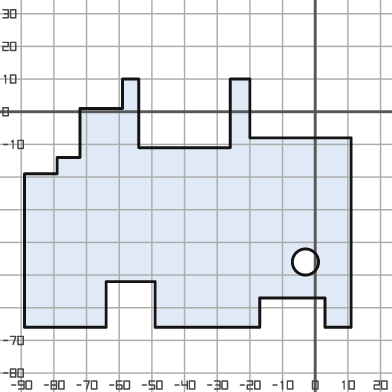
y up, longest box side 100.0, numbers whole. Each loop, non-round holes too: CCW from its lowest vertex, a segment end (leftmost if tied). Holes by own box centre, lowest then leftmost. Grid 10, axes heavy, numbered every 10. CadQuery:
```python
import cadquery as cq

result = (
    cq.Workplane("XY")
    .moveTo(-89.0, -66.0)
    .lineTo(-64.0, -66.0)
    .lineTo(-64.0, -52.0)
    .lineTo(-49.0, -52.0)
    .lineTo(-49.0, -66.0)
    .lineTo(-17.0, -66.0)
    .lineTo(-17.0, -57.0)
    .lineTo(3.0, -57.0)
    .lineTo(3.0, -66.0)
    .lineTo(11.0, -66.0)
    .lineTo(11.0, -8.0)
    .lineTo(-20.0, -8.0)
    .lineTo(-20.0, 10.0)
    .lineTo(-26.0, 10.0)
    .lineTo(-26.0, -11.0)
    .lineTo(-54.0, -11.0)
    .lineTo(-54.0, 10.0)
    .lineTo(-59.0, 10.0)
    .lineTo(-59.0, 1.0)
    .lineTo(-72.0, 1.0)
    .lineTo(-72.0, -14.0)
    .lineTo(-79.0, -14.0)
    .lineTo(-79.0, -19.0)
    .lineTo(-89.0, -19.0)
    .close()
    .moveTo(-3.0, -46.0)
    .circle(4.0)
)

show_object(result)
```